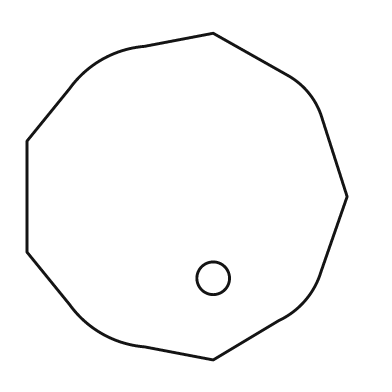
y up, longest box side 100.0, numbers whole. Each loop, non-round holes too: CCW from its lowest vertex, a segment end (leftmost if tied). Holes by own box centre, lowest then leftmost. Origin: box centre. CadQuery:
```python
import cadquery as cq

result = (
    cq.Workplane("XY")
    .moveTo(8.0, -50.0)
    .lineTo(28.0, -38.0)
    .threePointArc((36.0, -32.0), (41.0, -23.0))
    .lineTo(49.0, 0.0)
    .lineTo(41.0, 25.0)
    .threePointArc((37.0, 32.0), (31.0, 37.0))
    .lineTo(8.0, 50.0)
    .lineTo(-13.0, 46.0)
    .threePointArc((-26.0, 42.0), (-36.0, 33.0))
    .lineTo(-49.0, 17.0)
    .lineTo(-49.0, -17.0)
    .lineTo(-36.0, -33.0)
    .threePointArc((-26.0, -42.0), (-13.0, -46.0))
    .close()
    .moveTo(8.0, -25.0)
    .circle(5.0)
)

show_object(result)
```